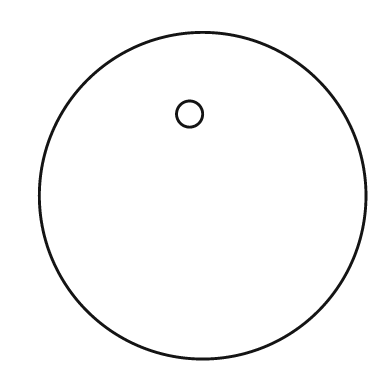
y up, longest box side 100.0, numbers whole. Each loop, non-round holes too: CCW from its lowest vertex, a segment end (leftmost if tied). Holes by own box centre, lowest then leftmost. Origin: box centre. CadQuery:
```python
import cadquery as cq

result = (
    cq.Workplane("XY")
    .moveTo(0.0, 0.0)
    .circle(50.0)
    .moveTo(-4.0, 25.0)
    .circle(4.0)
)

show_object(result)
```